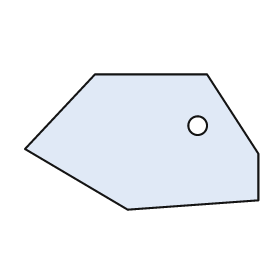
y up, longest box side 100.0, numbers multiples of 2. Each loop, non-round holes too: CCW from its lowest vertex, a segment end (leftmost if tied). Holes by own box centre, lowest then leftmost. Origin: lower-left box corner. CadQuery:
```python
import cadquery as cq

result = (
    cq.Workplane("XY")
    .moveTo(44.0, 0.0)
    .lineTo(100.0, 4.0)
    .lineTo(100.0, 24.0)
    .lineTo(78.0, 58.0)
    .lineTo(30.0, 58.0)
    .lineTo(0.0, 26.0)
    .close()
    .moveTo(74.0, 36.0)
    .circle(4.0)
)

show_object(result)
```